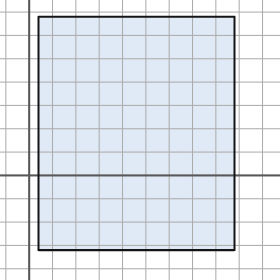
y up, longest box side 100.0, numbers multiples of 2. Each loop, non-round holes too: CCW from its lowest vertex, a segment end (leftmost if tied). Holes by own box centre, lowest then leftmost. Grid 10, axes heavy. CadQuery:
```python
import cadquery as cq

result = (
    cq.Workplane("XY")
    .moveTo(4.0, -32.0)
    .lineTo(88.0, -32.0)
    .lineTo(88.0, 68.0)
    .lineTo(4.0, 68.0)
    .close()
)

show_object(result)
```